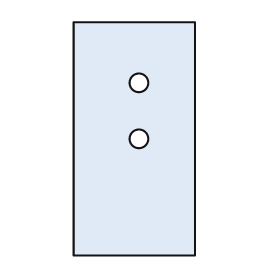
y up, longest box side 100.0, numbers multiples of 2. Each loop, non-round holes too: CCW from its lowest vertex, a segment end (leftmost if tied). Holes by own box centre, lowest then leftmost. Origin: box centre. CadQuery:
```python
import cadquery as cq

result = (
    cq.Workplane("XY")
    .moveTo(-26.0, -50.0)
    .lineTo(26.0, -50.0)
    .lineTo(26.0, 50.0)
    .lineTo(-26.0, 50.0)
    .close()
    .moveTo(2.0, 0.0)
    .circle(4.0)
    .moveTo(2.0, 24.0)
    .circle(4.0)
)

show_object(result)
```